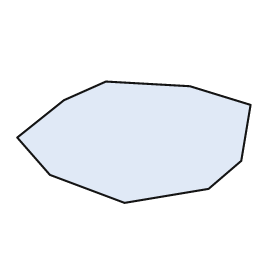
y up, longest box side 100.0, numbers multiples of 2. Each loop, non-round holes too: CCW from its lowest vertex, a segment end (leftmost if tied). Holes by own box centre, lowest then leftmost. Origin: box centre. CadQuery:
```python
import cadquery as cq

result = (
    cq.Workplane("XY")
    .moveTo(-4.0, -26.0)
    .lineTo(32.0, -20.0)
    .lineTo(46.0, -8.0)
    .lineTo(50.0, 16.0)
    .lineTo(24.0, 24.0)
    .lineTo(-12.0, 26.0)
    .lineTo(-30.0, 18.0)
    .lineTo(-50.0, 2.0)
    .lineTo(-36.0, -14.0)
    .close()
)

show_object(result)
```